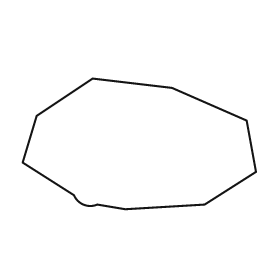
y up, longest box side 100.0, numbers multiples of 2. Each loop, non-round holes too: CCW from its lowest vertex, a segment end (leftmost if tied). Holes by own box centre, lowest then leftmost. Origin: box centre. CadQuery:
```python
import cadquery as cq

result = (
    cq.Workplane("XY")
    .moveTo(-6.0, -28.0)
    .lineTo(28.0, -26.0)
    .lineTo(50.0, -12.0)
    .lineTo(46.0, 10.0)
    .lineTo(14.0, 24.0)
    .lineTo(-20.0, 28.0)
    .lineTo(-44.0, 12.0)
    .lineTo(-50.0, -8.0)
    .lineTo(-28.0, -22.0)
    .threePointArc((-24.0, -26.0), (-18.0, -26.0))
    .close()
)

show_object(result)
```